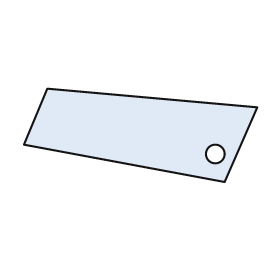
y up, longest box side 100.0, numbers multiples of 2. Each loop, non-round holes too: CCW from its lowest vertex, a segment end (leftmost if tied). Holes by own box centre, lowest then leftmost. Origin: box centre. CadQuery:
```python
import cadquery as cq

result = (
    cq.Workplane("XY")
    .moveTo(36.0, -20.0)
    .lineTo(50.0, 12.0)
    .lineTo(-40.0, 20.0)
    .lineTo(-50.0, -4.0)
    .close()
    .moveTo(32.0, -8.0)
    .circle(4.0)
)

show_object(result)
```